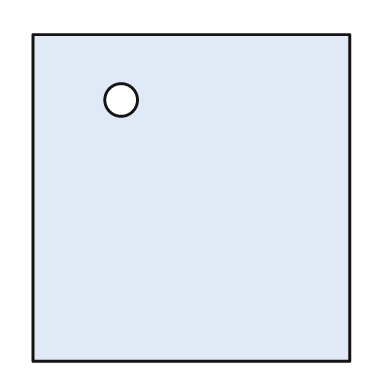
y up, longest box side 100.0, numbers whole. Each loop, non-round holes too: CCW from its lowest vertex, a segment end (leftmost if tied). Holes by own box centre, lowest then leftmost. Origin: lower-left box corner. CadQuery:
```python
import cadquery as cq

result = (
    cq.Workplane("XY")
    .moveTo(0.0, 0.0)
    .lineTo(97.0, 0.0)
    .lineTo(97.0, 100.0)
    .lineTo(0.0, 100.0)
    .close()
    .moveTo(27.0, 80.0)
    .circle(5.0)
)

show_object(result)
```